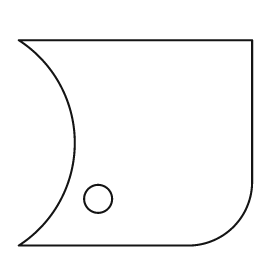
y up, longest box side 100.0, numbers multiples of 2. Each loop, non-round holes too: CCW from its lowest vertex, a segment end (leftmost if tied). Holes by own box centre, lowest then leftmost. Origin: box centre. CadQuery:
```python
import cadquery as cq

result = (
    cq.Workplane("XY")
    .moveTo(-50.0, -44.0)
    .lineTo(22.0, -44.0)
    .threePointArc((42.0, -36.0), (50.0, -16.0))
    .lineTo(50.0, 44.0)
    .lineTo(-50.0, 44.0)
    .threePointArc((-26.0, 0.0), (-50.0, -44.0))
    .close()
    .moveTo(-16.0, -24.0)
    .circle(6.0)
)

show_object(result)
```